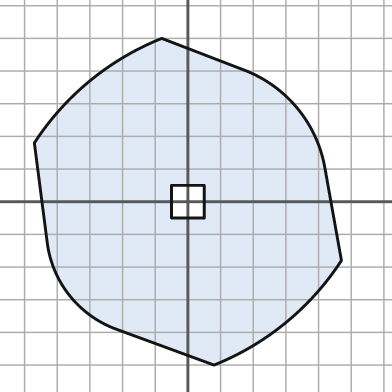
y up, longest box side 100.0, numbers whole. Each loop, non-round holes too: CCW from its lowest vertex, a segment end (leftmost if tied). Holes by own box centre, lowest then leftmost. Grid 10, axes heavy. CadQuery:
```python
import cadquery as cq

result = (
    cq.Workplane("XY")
    .moveTo(8.0, -50.0)
    .threePointArc((30.0, -37.0), (47.0, -18.0))
    .lineTo(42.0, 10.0)
    .threePointArc((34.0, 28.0), (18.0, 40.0))
    .lineTo(-8.0, 50.0)
    .threePointArc((-30.0, 37.0), (-47.0, 18.0))
    .lineTo(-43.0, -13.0)
    .threePointArc((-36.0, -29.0), (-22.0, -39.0))
    .close()
    .moveTo(-5.0, -5.0)
    .lineTo(5.0, -5.0)
    .lineTo(5.0, 5.0)
    .lineTo(-5.0, 5.0)
    .close()
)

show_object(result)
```